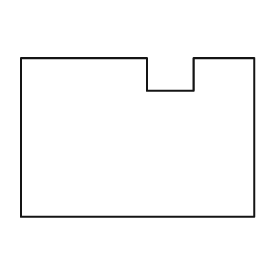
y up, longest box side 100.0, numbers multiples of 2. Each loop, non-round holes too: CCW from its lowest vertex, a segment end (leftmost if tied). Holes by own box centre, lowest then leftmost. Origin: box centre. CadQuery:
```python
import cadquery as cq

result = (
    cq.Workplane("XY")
    .moveTo(-50.0, -34.0)
    .lineTo(50.0, -34.0)
    .lineTo(50.0, 34.0)
    .lineTo(24.0, 34.0)
    .lineTo(24.0, 20.0)
    .lineTo(4.0, 20.0)
    .lineTo(4.0, 34.0)
    .lineTo(-50.0, 34.0)
    .close()
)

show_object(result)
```